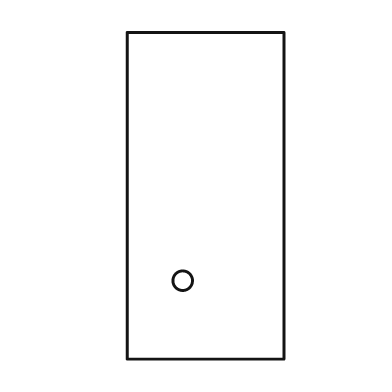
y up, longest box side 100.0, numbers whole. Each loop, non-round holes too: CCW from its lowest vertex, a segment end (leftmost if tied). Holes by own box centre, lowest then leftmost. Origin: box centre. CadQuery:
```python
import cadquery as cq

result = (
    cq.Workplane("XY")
    .moveTo(-24.0, -50.0)
    .lineTo(24.0, -50.0)
    .lineTo(24.0, 50.0)
    .lineTo(-24.0, 50.0)
    .close()
    .moveTo(-7.0, -26.0)
    .circle(3.0)
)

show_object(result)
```